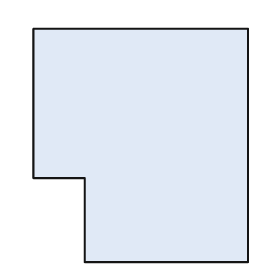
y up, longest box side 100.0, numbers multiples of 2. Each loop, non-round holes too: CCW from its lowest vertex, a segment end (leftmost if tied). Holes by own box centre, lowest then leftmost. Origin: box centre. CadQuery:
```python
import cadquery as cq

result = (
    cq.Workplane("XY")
    .moveTo(-24.0, -50.0)
    .lineTo(46.0, -50.0)
    .lineTo(46.0, 50.0)
    .lineTo(-46.0, 50.0)
    .lineTo(-46.0, -14.0)
    .lineTo(-24.0, -14.0)
    .close()
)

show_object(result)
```